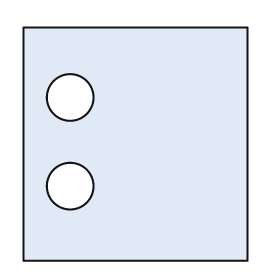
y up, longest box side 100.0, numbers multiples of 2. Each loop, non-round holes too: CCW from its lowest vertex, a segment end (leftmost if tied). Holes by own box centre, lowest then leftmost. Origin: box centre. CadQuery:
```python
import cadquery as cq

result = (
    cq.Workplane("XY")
    .moveTo(-48.0, -50.0)
    .lineTo(48.0, -50.0)
    .lineTo(48.0, 50.0)
    .lineTo(-48.0, 50.0)
    .close()
    .moveTo(-28.0, -18.0)
    .circle(10.0)
    .moveTo(-28.0, 20.0)
    .circle(10.0)
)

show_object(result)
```